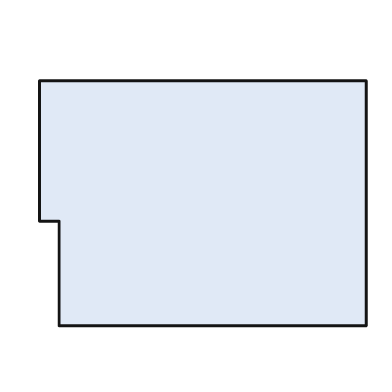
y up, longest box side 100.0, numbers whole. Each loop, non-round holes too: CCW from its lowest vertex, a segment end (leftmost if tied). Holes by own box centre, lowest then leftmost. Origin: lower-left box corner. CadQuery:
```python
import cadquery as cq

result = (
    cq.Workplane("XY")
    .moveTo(6.0, 0.0)
    .lineTo(100.0, 0.0)
    .lineTo(100.0, 75.0)
    .lineTo(0.0, 75.0)
    .lineTo(0.0, 32.0)
    .lineTo(6.0, 32.0)
    .close()
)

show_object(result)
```